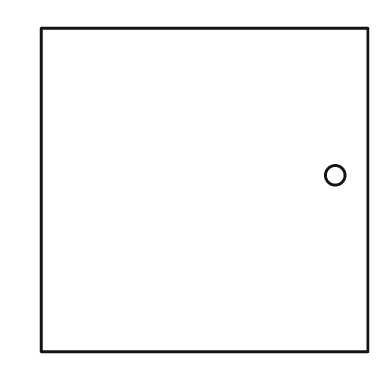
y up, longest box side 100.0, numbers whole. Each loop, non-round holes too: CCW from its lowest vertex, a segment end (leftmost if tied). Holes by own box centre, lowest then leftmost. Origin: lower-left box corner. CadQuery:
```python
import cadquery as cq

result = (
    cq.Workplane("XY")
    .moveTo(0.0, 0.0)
    .lineTo(100.0, 0.0)
    .lineTo(100.0, 99.0)
    .lineTo(0.0, 99.0)
    .close()
    .moveTo(90.0, 54.0)
    .circle(3.0)
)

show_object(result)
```